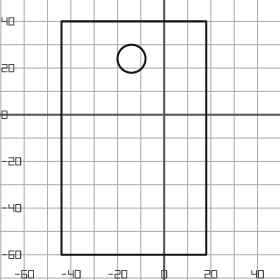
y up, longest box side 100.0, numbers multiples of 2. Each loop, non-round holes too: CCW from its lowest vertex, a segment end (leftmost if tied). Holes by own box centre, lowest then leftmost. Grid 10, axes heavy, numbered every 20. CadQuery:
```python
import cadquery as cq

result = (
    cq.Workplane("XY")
    .moveTo(-44.0, -60.0)
    .lineTo(18.0, -60.0)
    .lineTo(18.0, 40.0)
    .lineTo(-44.0, 40.0)
    .close()
    .moveTo(-14.0, 24.0)
    .circle(6.0)
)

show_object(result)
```